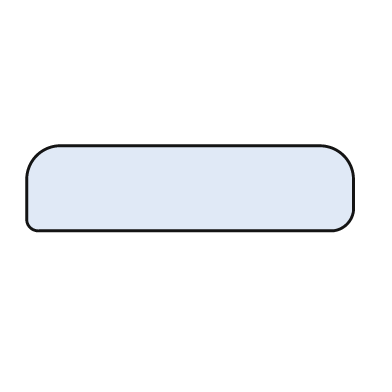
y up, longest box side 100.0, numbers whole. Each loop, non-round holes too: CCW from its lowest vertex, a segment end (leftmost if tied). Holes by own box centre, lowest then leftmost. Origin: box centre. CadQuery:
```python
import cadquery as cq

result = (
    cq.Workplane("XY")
    .moveTo(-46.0, -13.0)
    .lineTo(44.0, -13.0)
    .threePointArc((48.0, -11.0), (50.0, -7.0))
    .lineTo(50.0, 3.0)
    .threePointArc((47.0, 10.0), (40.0, 13.0))
    .lineTo(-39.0, 13.0)
    .threePointArc((-47.0, 10.0), (-50.0, 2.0))
    .lineTo(-50.0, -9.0)
    .threePointArc((-49.0, -12.0), (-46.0, -13.0))
    .close()
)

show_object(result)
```